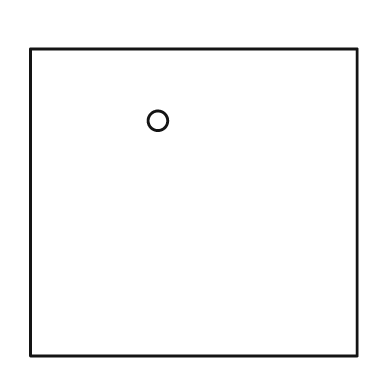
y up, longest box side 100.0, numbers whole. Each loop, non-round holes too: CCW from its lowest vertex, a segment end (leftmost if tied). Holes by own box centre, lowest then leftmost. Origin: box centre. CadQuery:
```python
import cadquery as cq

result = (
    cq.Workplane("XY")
    .moveTo(-50.0, -47.0)
    .lineTo(50.0, -47.0)
    .lineTo(50.0, 47.0)
    .lineTo(-50.0, 47.0)
    .close()
    .moveTo(-11.0, 25.0)
    .circle(3.0)
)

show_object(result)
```